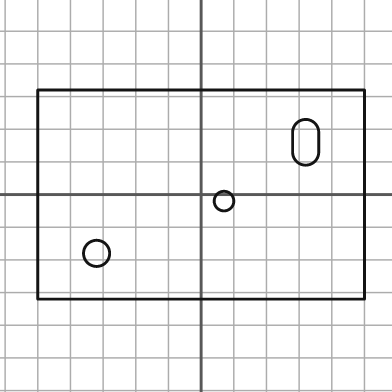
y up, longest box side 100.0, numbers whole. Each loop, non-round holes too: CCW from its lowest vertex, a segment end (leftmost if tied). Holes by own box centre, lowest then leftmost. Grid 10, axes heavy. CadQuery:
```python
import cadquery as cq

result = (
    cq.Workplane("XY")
    .moveTo(-50.0, -32.0)
    .lineTo(50.0, -32.0)
    .lineTo(50.0, 32.0)
    .lineTo(-50.0, 32.0)
    .close()
    .moveTo(-32.0, -18.0)
    .circle(4.0)
    .moveTo(7.0, -2.0)
    .circle(3.0)
    .moveTo(28.0, 13.0)
    .threePointArc((32.0, 9.0), (36.0, 13.0))
    .lineTo(36.0, 19.0)
    .threePointArc((32.0, 23.0), (28.0, 19.0))
    .close()
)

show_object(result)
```